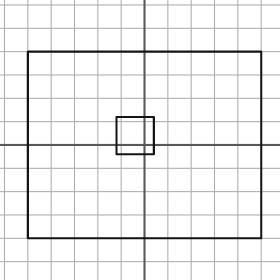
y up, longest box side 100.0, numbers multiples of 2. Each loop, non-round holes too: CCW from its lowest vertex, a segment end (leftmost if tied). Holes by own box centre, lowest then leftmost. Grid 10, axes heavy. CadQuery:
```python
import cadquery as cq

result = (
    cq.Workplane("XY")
    .moveTo(-50.0, -40.0)
    .lineTo(50.0, -40.0)
    .lineTo(50.0, 40.0)
    .lineTo(-50.0, 40.0)
    .close()
    .moveTo(-12.0, -4.0)
    .lineTo(4.0, -4.0)
    .lineTo(4.0, 12.0)
    .lineTo(-12.0, 12.0)
    .close()
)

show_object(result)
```